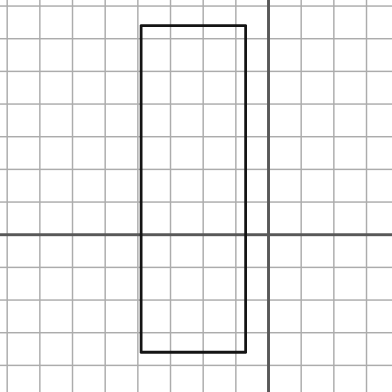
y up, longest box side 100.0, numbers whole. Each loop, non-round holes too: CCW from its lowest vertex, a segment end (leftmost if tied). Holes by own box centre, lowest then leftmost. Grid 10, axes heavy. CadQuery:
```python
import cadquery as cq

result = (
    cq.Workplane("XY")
    .moveTo(-39.0, -36.0)
    .lineTo(-7.0, -36.0)
    .lineTo(-7.0, 64.0)
    .lineTo(-39.0, 64.0)
    .close()
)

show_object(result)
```